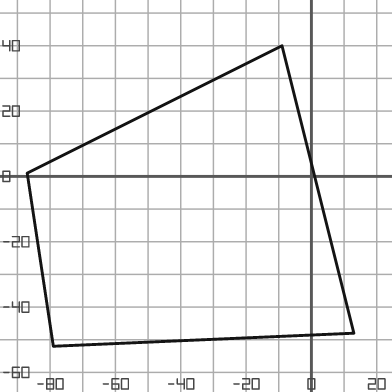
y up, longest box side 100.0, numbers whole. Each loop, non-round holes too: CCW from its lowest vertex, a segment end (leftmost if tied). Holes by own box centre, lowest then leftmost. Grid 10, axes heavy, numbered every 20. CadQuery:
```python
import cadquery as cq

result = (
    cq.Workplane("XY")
    .moveTo(-79.0, -52.0)
    .lineTo(13.0, -48.0)
    .lineTo(-9.0, 40.0)
    .lineTo(-87.0, 1.0)
    .close()
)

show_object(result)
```